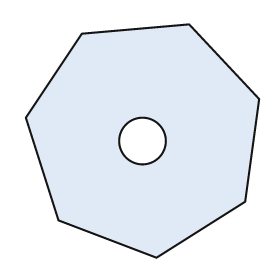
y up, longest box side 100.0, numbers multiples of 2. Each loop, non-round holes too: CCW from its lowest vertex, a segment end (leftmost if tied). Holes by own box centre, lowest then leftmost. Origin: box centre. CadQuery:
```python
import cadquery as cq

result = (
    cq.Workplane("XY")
    .moveTo(6.0, -50.0)
    .lineTo(44.0, -26.0)
    .lineTo(50.0, 18.0)
    .lineTo(20.0, 50.0)
    .lineTo(-26.0, 46.0)
    .lineTo(-50.0, 10.0)
    .lineTo(-36.0, -34.0)
    .close()
    .moveTo(0.0, 0.0)
    .circle(10.0)
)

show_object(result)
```